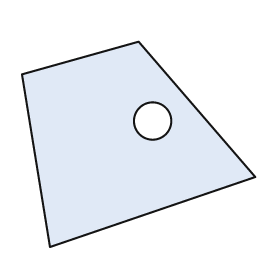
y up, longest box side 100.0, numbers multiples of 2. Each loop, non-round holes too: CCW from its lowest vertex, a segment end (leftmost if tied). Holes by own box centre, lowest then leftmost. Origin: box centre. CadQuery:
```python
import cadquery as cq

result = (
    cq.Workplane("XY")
    .moveTo(-38.0, -44.0)
    .lineTo(50.0, -14.0)
    .lineTo(0.0, 44.0)
    .lineTo(-50.0, 30.0)
    .close()
    .moveTo(6.0, 10.0)
    .circle(8.0)
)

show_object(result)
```